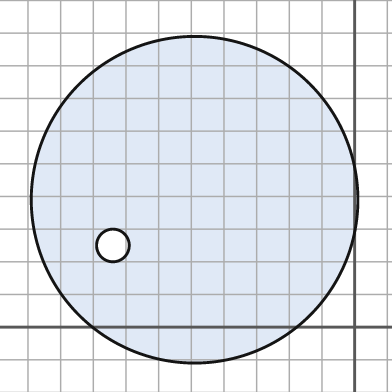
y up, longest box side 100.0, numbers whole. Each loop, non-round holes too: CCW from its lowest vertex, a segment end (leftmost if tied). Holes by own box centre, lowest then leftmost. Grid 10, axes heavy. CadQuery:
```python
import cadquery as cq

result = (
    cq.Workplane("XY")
    .moveTo(-49.0, 39.0)
    .circle(50.0)
    .moveTo(-74.0, 25.0)
    .circle(5.0)
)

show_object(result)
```